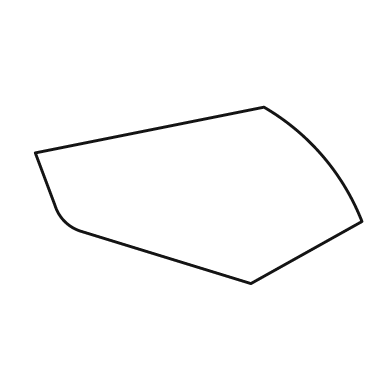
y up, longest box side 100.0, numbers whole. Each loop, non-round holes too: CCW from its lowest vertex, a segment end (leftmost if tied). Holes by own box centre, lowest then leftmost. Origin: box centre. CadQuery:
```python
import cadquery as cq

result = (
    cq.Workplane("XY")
    .moveTo(16.0, -27.0)
    .lineTo(50.0, -8.0)
    .threePointArc((38.0, 12.0), (20.0, 27.0))
    .lineTo(-50.0, 13.0)
    .lineTo(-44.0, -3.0)
    .threePointArc((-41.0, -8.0), (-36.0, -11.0))
    .close()
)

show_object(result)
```